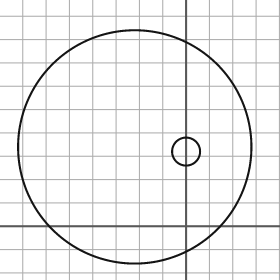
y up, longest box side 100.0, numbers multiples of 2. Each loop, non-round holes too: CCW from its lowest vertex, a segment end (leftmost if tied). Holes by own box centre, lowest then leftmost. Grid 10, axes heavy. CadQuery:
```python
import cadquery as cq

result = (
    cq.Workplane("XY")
    .moveTo(-22.0, 34.0)
    .circle(50.0)
    .moveTo(0.0, 32.0)
    .circle(6.0)
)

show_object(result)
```